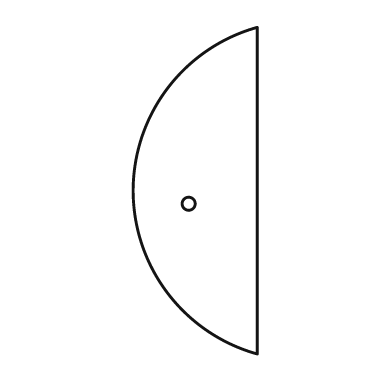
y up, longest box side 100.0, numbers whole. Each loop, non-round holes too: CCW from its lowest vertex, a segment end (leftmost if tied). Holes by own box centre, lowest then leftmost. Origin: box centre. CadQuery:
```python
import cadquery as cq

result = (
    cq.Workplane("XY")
    .moveTo(19.0, -50.0)
    .lineTo(19.0, 50.0)
    .threePointArc((-19.0, 0.0), (19.0, -50.0))
    .close()
    .moveTo(-2.0, -4.0)
    .circle(2.0)
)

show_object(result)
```